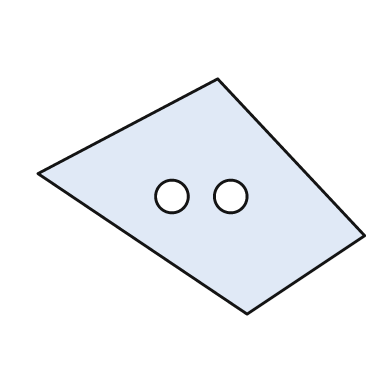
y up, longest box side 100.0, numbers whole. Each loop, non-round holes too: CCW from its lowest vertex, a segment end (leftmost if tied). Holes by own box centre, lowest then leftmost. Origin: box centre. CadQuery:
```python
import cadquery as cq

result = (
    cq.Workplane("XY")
    .moveTo(14.0, -36.0)
    .lineTo(50.0, -12.0)
    .lineTo(5.0, 36.0)
    .lineTo(-50.0, 7.0)
    .close()
    .moveTo(-9.0, 0.0)
    .circle(5.0)
    .moveTo(9.0, 0.0)
    .circle(5.0)
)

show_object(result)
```